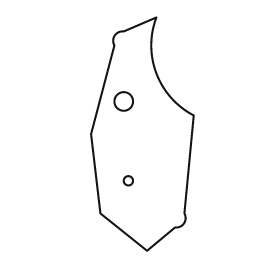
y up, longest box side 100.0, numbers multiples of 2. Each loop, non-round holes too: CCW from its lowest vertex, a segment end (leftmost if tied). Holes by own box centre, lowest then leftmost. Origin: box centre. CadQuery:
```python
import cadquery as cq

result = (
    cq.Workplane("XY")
    .moveTo(2.0, -50.0)
    .lineTo(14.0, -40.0)
    .threePointArc((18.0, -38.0), (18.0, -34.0))
    .lineTo(22.0, 8.0)
    .threePointArc((6.0, 26.0), (6.0, 50.0))
    .lineTo(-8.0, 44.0)
    .threePointArc((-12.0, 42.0), (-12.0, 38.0))
    .lineTo(-22.0, 0.0)
    .lineTo(-18.0, -34.0)
    .close()
    .moveTo(-6.0, -20.0)
    .circle(2.0)
    .moveTo(-8.0, 14.0)
    .circle(4.0)
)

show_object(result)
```